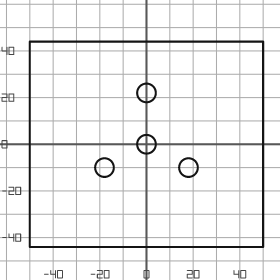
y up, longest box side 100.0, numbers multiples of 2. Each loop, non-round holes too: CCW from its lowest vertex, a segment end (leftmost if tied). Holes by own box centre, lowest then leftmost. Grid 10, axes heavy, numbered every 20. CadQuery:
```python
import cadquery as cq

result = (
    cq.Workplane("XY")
    .moveTo(-50.0, -44.0)
    .lineTo(50.0, -44.0)
    .lineTo(50.0, 44.0)
    .lineTo(-50.0, 44.0)
    .close()
    .moveTo(-18.0, -10.0)
    .circle(4.0)
    .moveTo(18.0, -10.0)
    .circle(4.0)
    .moveTo(0.0, 0.0)
    .circle(4.0)
    .moveTo(0.0, 22.0)
    .circle(4.0)
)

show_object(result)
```